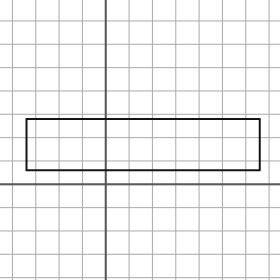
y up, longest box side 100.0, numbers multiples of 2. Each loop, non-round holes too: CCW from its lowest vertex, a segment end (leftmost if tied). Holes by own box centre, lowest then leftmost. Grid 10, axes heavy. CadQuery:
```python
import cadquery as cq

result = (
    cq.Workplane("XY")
    .moveTo(-34.0, 6.0)
    .lineTo(66.0, 6.0)
    .lineTo(66.0, 28.0)
    .lineTo(-34.0, 28.0)
    .close()
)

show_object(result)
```